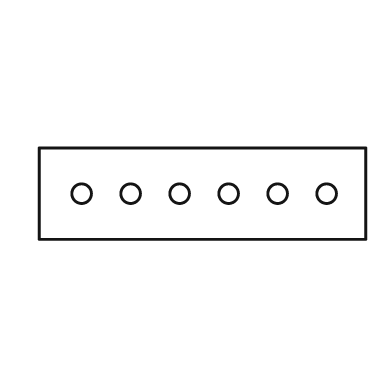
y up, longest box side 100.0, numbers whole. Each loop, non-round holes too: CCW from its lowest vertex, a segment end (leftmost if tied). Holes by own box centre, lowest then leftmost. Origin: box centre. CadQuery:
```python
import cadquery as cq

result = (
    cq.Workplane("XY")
    .moveTo(-50.0, -14.0)
    .lineTo(50.0, -14.0)
    .lineTo(50.0, 14.0)
    .lineTo(-50.0, 14.0)
    .close()
    .moveTo(-37.0, 0.0)
    .circle(3.0)
    .moveTo(-22.0, 0.0)
    .circle(3.0)
    .moveTo(-7.0, 0.0)
    .circle(3.0)
    .moveTo(8.0, 0.0)
    .circle(3.0)
    .moveTo(23.0, 0.0)
    .circle(3.0)
    .moveTo(38.0, 0.0)
    .circle(3.0)
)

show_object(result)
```